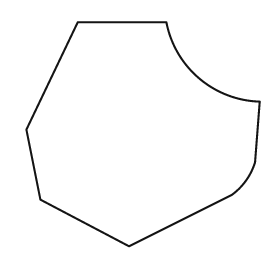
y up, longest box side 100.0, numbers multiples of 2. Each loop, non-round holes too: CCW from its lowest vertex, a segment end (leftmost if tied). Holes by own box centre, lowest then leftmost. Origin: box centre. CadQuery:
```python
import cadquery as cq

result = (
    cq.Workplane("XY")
    .moveTo(-6.0, -48.0)
    .lineTo(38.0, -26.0)
    .threePointArc((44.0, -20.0), (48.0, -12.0))
    .lineTo(50.0, 14.0)
    .threePointArc((24.0, 24.0), (10.0, 48.0))
    .lineTo(-28.0, 48.0)
    .lineTo(-50.0, 2.0)
    .lineTo(-44.0, -28.0)
    .close()
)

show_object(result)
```